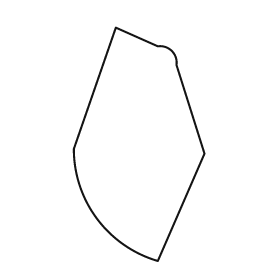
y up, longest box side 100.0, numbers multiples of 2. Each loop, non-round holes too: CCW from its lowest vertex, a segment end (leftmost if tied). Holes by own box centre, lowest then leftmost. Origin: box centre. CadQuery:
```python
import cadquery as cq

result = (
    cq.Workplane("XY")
    .moveTo(8.0, -50.0)
    .lineTo(28.0, -4.0)
    .lineTo(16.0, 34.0)
    .threePointArc((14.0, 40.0), (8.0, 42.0))
    .lineTo(-10.0, 50.0)
    .lineTo(-28.0, -2.0)
    .threePointArc((-18.0, -32.0), (8.0, -50.0))
    .close()
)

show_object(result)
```